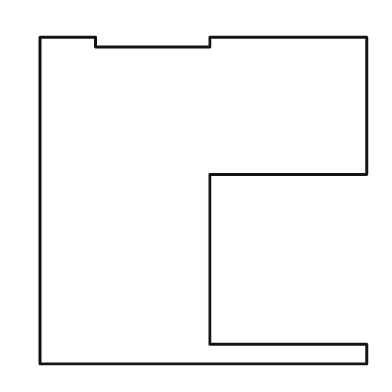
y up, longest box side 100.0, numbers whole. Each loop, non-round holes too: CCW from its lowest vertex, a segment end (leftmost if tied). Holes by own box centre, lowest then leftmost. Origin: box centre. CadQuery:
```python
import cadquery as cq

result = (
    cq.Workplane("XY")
    .moveTo(-50.0, -50.0)
    .lineTo(50.0, -50.0)
    .lineTo(50.0, -44.0)
    .lineTo(2.0, -44.0)
    .lineTo(2.0, 8.0)
    .lineTo(50.0, 8.0)
    .lineTo(50.0, 50.0)
    .lineTo(2.0, 50.0)
    .lineTo(2.0, 47.0)
    .lineTo(-33.0, 47.0)
    .lineTo(-33.0, 50.0)
    .lineTo(-50.0, 50.0)
    .close()
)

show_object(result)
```